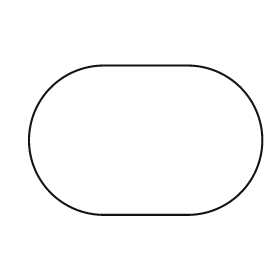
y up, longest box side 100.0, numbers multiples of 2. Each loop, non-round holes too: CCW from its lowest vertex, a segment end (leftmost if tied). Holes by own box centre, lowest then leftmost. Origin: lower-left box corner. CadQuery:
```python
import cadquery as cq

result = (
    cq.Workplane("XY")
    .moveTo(32.0, 0.0)
    .lineTo(68.0, 0.0)
    .threePointArc((100.0, 32.0), (68.0, 64.0))
    .lineTo(32.0, 64.0)
    .threePointArc((0.0, 32.0), (32.0, 0.0))
    .close()
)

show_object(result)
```